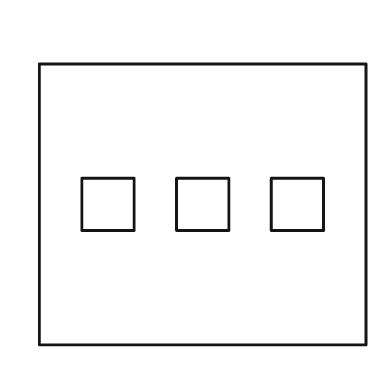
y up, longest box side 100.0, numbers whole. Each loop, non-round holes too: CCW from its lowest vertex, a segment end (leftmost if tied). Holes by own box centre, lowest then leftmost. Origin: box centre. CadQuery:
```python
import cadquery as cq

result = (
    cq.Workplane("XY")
    .moveTo(-50.0, -43.0)
    .lineTo(50.0, -43.0)
    .lineTo(50.0, 43.0)
    .lineTo(-50.0, 43.0)
    .close()
    .moveTo(-37.0, -8.0)
    .lineTo(-21.0, -8.0)
    .lineTo(-21.0, 8.0)
    .lineTo(-37.0, 8.0)
    .close()
    .moveTo(-8.0, -8.0)
    .lineTo(8.0, -8.0)
    .lineTo(8.0, 8.0)
    .lineTo(-8.0, 8.0)
    .close()
    .moveTo(21.0, -8.0)
    .lineTo(37.0, -8.0)
    .lineTo(37.0, 8.0)
    .lineTo(21.0, 8.0)
    .close()
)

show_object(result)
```